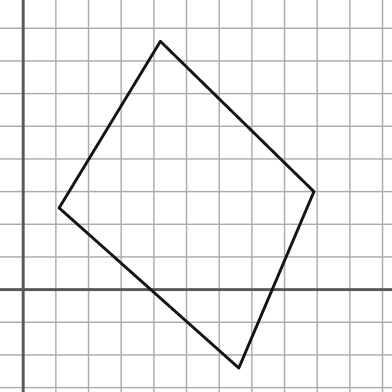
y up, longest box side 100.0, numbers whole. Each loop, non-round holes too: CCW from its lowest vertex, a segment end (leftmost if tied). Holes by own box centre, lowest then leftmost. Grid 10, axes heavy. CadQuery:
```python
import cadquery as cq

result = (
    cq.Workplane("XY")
    .moveTo(66.0, -24.0)
    .lineTo(89.0, 30.0)
    .lineTo(42.0, 76.0)
    .lineTo(11.0, 25.0)
    .close()
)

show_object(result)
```